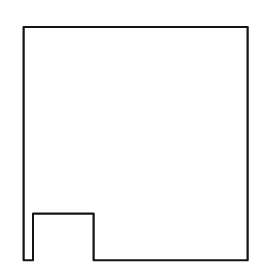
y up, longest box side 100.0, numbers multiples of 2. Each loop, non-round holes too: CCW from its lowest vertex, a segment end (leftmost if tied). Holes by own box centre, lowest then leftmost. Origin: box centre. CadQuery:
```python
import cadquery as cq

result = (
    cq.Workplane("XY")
    .moveTo(-48.0, -50.0)
    .lineTo(-44.0, -50.0)
    .lineTo(-44.0, -30.0)
    .lineTo(-18.0, -30.0)
    .lineTo(-18.0, -50.0)
    .lineTo(48.0, -50.0)
    .lineTo(48.0, 50.0)
    .lineTo(-48.0, 50.0)
    .close()
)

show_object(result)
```